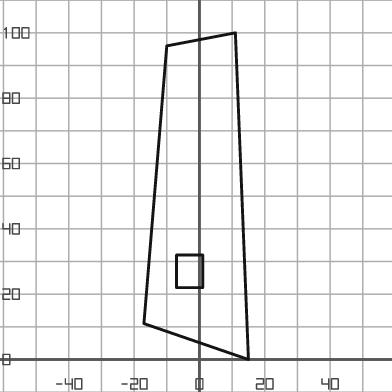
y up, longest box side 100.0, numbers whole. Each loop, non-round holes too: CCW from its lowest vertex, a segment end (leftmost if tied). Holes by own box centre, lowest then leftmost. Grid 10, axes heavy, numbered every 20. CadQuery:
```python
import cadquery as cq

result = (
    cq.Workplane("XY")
    .moveTo(15.0, 0.0)
    .lineTo(11.0, 100.0)
    .lineTo(-10.0, 96.0)
    .lineTo(-17.0, 11.0)
    .close()
    .moveTo(-7.0, 22.0)
    .lineTo(1.0, 22.0)
    .lineTo(1.0, 32.0)
    .lineTo(-7.0, 32.0)
    .close()
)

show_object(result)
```